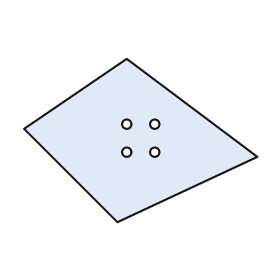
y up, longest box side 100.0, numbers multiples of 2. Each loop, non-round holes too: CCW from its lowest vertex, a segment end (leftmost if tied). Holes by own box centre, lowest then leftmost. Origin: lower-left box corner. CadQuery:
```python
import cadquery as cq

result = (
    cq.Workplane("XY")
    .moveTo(40.0, 0.0)
    .lineTo(100.0, 28.0)
    .lineTo(44.0, 70.0)
    .lineTo(0.0, 40.0)
    .close()
    .moveTo(44.0, 30.0)
    .circle(2.0)
    .moveTo(56.0, 30.0)
    .circle(2.0)
    .moveTo(44.0, 42.0)
    .circle(2.0)
    .moveTo(56.0, 42.0)
    .circle(2.0)
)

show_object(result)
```